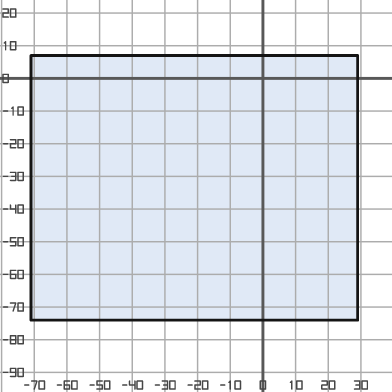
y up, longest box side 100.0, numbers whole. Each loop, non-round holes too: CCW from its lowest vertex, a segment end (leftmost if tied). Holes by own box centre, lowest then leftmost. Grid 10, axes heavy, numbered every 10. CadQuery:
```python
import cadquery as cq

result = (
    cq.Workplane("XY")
    .moveTo(-71.0, -74.0)
    .lineTo(29.0, -74.0)
    .lineTo(29.0, 7.0)
    .lineTo(-71.0, 7.0)
    .close()
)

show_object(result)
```